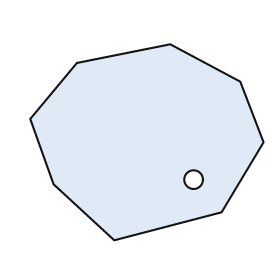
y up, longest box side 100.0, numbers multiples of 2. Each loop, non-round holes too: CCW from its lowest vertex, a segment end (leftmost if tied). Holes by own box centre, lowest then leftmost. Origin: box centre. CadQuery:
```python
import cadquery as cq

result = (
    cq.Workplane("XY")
    .moveTo(-14.0, -42.0)
    .lineTo(32.0, -30.0)
    .lineTo(50.0, 0.0)
    .lineTo(40.0, 26.0)
    .lineTo(10.0, 42.0)
    .lineTo(-30.0, 34.0)
    .lineTo(-50.0, 10.0)
    .lineTo(-40.0, -18.0)
    .close()
    .moveTo(20.0, -16.0)
    .circle(4.0)
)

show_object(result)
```